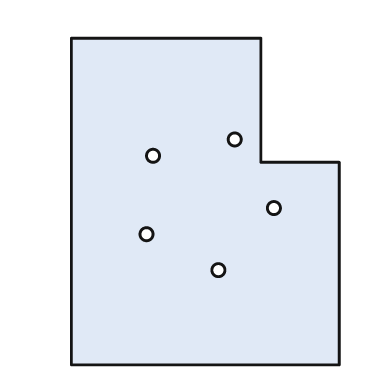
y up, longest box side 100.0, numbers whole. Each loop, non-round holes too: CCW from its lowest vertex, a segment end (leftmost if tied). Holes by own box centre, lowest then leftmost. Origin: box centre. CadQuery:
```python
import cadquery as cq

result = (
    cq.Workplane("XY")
    .moveTo(-41.0, -50.0)
    .lineTo(41.0, -50.0)
    .lineTo(41.0, 12.0)
    .lineTo(17.0, 12.0)
    .lineTo(17.0, 50.0)
    .lineTo(-41.0, 50.0)
    .close()
    .moveTo(4.0, -21.0)
    .circle(2.0)
    .moveTo(-18.0, -10.0)
    .circle(2.0)
    .moveTo(21.0, -2.0)
    .circle(2.0)
    .moveTo(-16.0, 14.0)
    .circle(2.0)
    .moveTo(9.0, 19.0)
    .circle(2.0)
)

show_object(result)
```